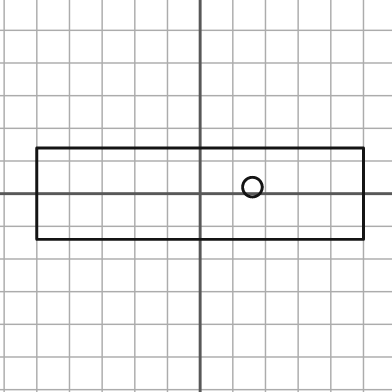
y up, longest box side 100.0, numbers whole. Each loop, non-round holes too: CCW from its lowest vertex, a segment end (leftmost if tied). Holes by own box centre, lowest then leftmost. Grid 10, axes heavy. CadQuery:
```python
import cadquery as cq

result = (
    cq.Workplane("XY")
    .moveTo(-50.0, -14.0)
    .lineTo(50.0, -14.0)
    .lineTo(50.0, 14.0)
    .lineTo(-50.0, 14.0)
    .close()
    .moveTo(16.0, 2.0)
    .circle(3.0)
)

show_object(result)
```